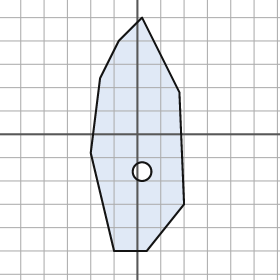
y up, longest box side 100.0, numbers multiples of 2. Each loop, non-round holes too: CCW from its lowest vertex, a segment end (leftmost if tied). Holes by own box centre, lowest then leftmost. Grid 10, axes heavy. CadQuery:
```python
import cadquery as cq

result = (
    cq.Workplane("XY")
    .moveTo(-10.0, -50.0)
    .lineTo(4.0, -50.0)
    .lineTo(20.0, -30.0)
    .lineTo(18.0, 18.0)
    .lineTo(2.0, 50.0)
    .lineTo(-8.0, 40.0)
    .lineTo(-16.0, 24.0)
    .lineTo(-20.0, -8.0)
    .close()
    .moveTo(2.0, -16.0)
    .circle(4.0)
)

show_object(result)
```